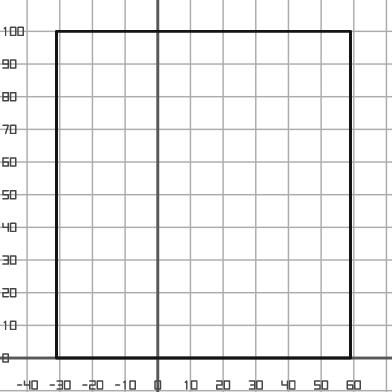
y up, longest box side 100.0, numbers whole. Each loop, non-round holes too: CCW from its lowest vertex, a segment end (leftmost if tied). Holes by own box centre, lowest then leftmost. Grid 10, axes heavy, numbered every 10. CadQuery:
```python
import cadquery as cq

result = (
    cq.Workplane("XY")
    .moveTo(-31.0, 0.0)
    .lineTo(59.0, 0.0)
    .lineTo(59.0, 100.0)
    .lineTo(-31.0, 100.0)
    .close()
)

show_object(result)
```